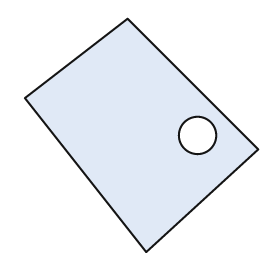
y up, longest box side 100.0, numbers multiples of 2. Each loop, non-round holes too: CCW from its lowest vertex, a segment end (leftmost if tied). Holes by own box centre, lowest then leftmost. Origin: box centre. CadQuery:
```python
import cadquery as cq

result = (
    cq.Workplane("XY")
    .moveTo(2.0, -50.0)
    .lineTo(50.0, -6.0)
    .lineTo(-6.0, 50.0)
    .lineTo(-50.0, 16.0)
    .close()
    .moveTo(24.0, 0.0)
    .circle(8.0)
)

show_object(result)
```